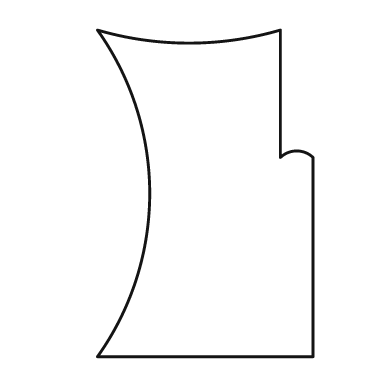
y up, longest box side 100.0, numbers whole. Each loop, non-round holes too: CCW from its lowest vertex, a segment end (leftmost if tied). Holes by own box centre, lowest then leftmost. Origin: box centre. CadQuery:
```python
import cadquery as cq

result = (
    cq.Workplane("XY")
    .moveTo(-33.0, -50.0)
    .lineTo(33.0, -50.0)
    .lineTo(33.0, 11.0)
    .threePointArc((28.0, 13.0), (23.0, 11.0))
    .lineTo(23.0, 50.0)
    .threePointArc((-5.0, 46.0), (-33.0, 50.0))
    .threePointArc((-17.0, 0.0), (-33.0, -50.0))
    .close()
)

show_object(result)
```